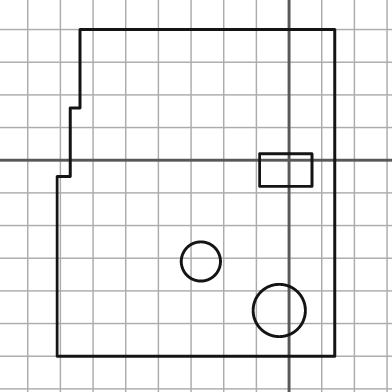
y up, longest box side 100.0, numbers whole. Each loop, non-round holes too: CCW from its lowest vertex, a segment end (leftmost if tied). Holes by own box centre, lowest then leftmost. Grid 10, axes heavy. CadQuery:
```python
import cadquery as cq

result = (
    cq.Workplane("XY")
    .moveTo(-71.0, -60.0)
    .lineTo(14.0, -60.0)
    .lineTo(14.0, 40.0)
    .lineTo(-64.0, 40.0)
    .lineTo(-64.0, 16.0)
    .lineTo(-67.0, 16.0)
    .lineTo(-67.0, -5.0)
    .lineTo(-71.0, -5.0)
    .close()
    .moveTo(-3.0, -46.0)
    .circle(8.0)
    .moveTo(-27.0, -31.0)
    .circle(6.0)
    .moveTo(-9.0, -8.0)
    .lineTo(7.0, -8.0)
    .lineTo(7.0, 2.0)
    .lineTo(-9.0, 2.0)
    .close()
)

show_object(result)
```